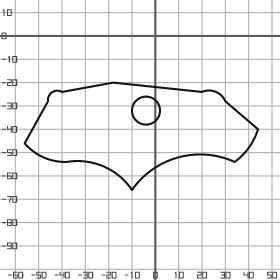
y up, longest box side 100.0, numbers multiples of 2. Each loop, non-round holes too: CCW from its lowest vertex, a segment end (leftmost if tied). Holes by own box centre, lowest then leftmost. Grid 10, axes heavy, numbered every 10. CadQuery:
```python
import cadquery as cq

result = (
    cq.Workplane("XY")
    .moveTo(-10.0, -66.0)
    .threePointArc((10.0, -52.0), (34.0, -54.0))
    .threePointArc((40.0, -48.0), (44.0, -40.0))
    .lineTo(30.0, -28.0)
    .threePointArc((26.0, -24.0), (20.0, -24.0))
    .lineTo(-18.0, -20.0)
    .lineTo(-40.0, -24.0)
    .threePointArc((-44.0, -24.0), (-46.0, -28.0))
    .lineTo(-56.0, -46.0)
    .threePointArc((-48.0, -52.0), (-38.0, -54.0))
    .threePointArc((-22.0, -56.0), (-10.0, -66.0))
    .close()
    .moveTo(-4.0, -32.0)
    .circle(6.0)
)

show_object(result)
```